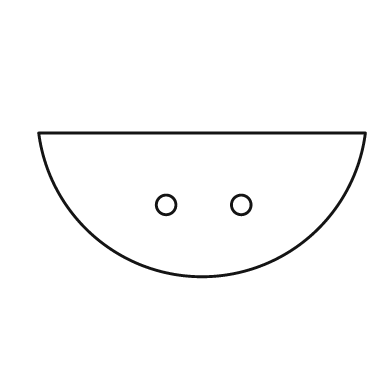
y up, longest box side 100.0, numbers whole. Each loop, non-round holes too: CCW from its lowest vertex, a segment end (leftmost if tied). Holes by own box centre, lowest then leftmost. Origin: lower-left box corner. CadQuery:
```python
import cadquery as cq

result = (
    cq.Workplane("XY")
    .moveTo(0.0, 44.0)
    .threePointArc((50.0, 0.0), (100.0, 44.0))
    .close()
    .moveTo(39.0, 22.0)
    .circle(3.0)
    .moveTo(62.0, 22.0)
    .circle(3.0)
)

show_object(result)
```